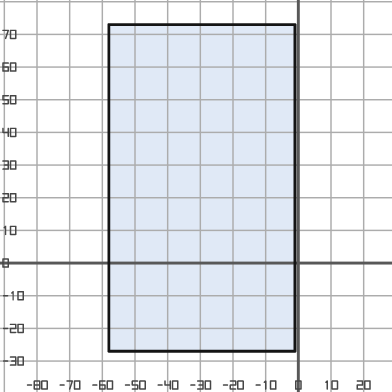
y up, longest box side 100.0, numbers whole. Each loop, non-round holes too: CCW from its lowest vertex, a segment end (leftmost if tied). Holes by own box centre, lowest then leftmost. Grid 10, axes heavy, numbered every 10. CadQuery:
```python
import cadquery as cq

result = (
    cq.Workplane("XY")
    .moveTo(-58.0, -27.0)
    .lineTo(-1.0, -27.0)
    .lineTo(-1.0, 73.0)
    .lineTo(-58.0, 73.0)
    .close()
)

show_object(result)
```